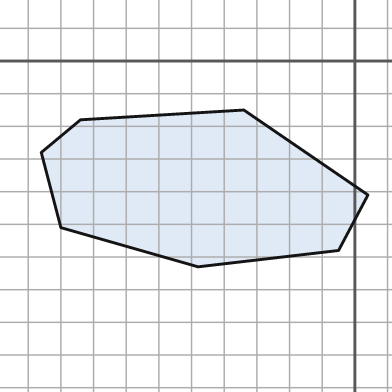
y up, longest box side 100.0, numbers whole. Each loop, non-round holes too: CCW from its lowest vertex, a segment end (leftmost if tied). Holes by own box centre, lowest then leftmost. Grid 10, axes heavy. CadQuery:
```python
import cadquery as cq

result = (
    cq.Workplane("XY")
    .moveTo(-48.0, -63.0)
    .lineTo(-5.0, -58.0)
    .lineTo(4.0, -41.0)
    .lineTo(-34.0, -15.0)
    .lineTo(-84.0, -18.0)
    .lineTo(-96.0, -28.0)
    .lineTo(-90.0, -51.0)
    .close()
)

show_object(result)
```